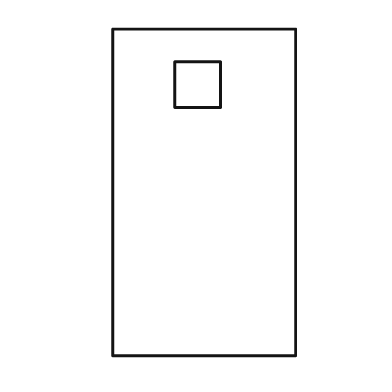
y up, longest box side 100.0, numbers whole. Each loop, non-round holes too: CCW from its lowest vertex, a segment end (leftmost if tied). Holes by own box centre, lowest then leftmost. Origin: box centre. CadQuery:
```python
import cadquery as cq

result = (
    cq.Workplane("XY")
    .moveTo(-28.0, -50.0)
    .lineTo(28.0, -50.0)
    .lineTo(28.0, 50.0)
    .lineTo(-28.0, 50.0)
    .close()
    .moveTo(-9.0, 26.0)
    .lineTo(5.0, 26.0)
    .lineTo(5.0, 40.0)
    .lineTo(-9.0, 40.0)
    .close()
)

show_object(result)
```